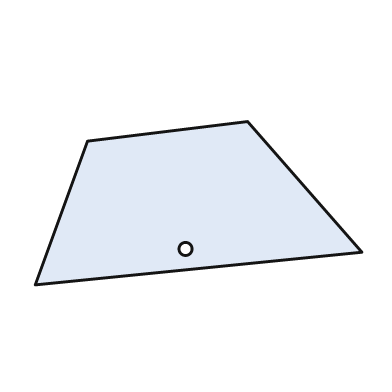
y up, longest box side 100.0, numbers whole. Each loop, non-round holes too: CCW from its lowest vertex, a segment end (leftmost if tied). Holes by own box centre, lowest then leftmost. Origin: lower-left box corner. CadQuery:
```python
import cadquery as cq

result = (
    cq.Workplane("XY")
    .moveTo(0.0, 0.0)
    .lineTo(100.0, 10.0)
    .lineTo(65.0, 50.0)
    .lineTo(16.0, 44.0)
    .close()
    .moveTo(46.0, 11.0)
    .circle(2.0)
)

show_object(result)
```